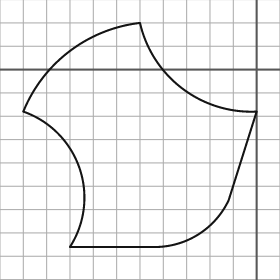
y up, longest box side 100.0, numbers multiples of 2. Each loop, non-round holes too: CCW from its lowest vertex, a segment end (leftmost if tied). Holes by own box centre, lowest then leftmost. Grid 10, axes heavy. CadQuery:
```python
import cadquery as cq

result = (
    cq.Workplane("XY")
    .moveTo(-80.0, -76.0)
    .lineTo(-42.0, -76.0)
    .threePointArc((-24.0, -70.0), (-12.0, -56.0))
    .lineTo(0.0, -18.0)
    .threePointArc((-32.0, -8.0), (-50.0, 20.0))
    .threePointArc((-80.0, 8.0), (-100.0, -18.0))
    .threePointArc((-76.0, -42.0), (-80.0, -76.0))
    .close()
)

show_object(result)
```